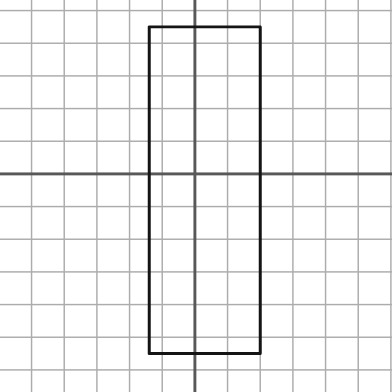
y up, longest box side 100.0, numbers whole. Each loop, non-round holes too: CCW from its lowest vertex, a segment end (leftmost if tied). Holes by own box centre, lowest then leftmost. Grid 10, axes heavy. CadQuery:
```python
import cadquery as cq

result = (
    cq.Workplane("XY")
    .moveTo(-14.0, -55.0)
    .lineTo(20.0, -55.0)
    .lineTo(20.0, 45.0)
    .lineTo(-14.0, 45.0)
    .close()
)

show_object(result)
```